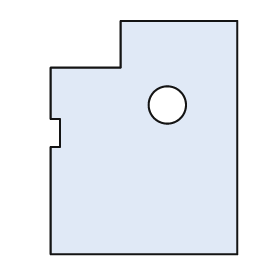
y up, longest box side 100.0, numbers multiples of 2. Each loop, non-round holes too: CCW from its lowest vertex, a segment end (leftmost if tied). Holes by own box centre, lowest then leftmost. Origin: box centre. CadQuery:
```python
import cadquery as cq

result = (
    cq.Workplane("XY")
    .moveTo(-40.0, -50.0)
    .lineTo(40.0, -50.0)
    .lineTo(40.0, 50.0)
    .lineTo(-10.0, 50.0)
    .lineTo(-10.0, 30.0)
    .lineTo(-40.0, 30.0)
    .lineTo(-40.0, 8.0)
    .lineTo(-36.0, 8.0)
    .lineTo(-36.0, -4.0)
    .lineTo(-40.0, -4.0)
    .close()
    .moveTo(10.0, 14.0)
    .circle(8.0)
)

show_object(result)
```